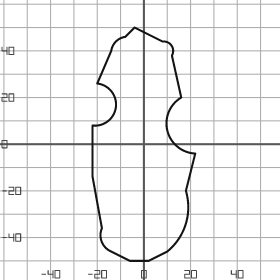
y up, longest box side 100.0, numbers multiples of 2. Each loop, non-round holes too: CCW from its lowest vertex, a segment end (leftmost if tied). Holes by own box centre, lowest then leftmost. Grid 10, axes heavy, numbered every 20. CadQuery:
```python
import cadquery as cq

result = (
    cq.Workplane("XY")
    .moveTo(-6.0, -50.0)
    .lineTo(2.0, -50.0)
    .lineTo(10.0, -46.0)
    .threePointArc((18.0, -34.0), (18.0, -20.0))
    .lineTo(22.0, -4.0)
    .threePointArc((10.0, 6.0), (16.0, 20.0))
    .lineTo(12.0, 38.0)
    .threePointArc((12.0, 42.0), (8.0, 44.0))
    .lineTo(-4.0, 50.0)
    .lineTo(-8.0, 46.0)
    .threePointArc((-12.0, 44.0), (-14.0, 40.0))
    .lineTo(-20.0, 26.0)
    .threePointArc((-12.0, 16.0), (-22.0, 8.0))
    .lineTo(-22.0, -14.0)
    .lineTo(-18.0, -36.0)
    .threePointArc((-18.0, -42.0), (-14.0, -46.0))
    .close()
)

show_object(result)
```